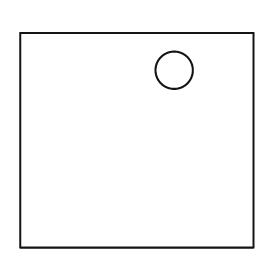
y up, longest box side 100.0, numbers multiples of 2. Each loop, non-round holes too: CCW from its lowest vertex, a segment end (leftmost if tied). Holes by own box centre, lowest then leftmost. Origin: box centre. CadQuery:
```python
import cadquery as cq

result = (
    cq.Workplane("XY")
    .moveTo(-50.0, -46.0)
    .lineTo(50.0, -46.0)
    .lineTo(50.0, 46.0)
    .lineTo(-50.0, 46.0)
    .close()
    .moveTo(16.0, 30.0)
    .circle(8.0)
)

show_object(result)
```